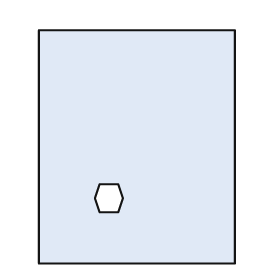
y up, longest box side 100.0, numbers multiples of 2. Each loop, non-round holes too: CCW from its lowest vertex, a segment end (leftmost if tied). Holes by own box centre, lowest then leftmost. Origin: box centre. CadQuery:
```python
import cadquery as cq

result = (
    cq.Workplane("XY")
    .moveTo(-42.0, -50.0)
    .lineTo(42.0, -50.0)
    .lineTo(42.0, 50.0)
    .lineTo(-42.0, 50.0)
    .close()
    .moveTo(-16.0, -28.0)
    .lineTo(-8.0, -28.0)
    .lineTo(-6.0, -22.0)
    .lineTo(-8.0, -16.0)
    .lineTo(-16.0, -16.0)
    .lineTo(-18.0, -22.0)
    .close()
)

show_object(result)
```